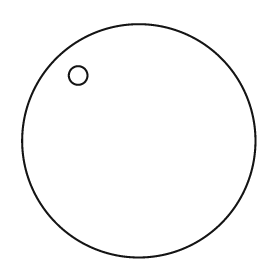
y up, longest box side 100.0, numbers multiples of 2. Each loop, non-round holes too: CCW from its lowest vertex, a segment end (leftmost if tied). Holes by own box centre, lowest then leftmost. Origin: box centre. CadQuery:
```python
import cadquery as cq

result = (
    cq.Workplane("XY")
    .moveTo(0.0, 0.0)
    .circle(50.0)
    .moveTo(-26.0, 28.0)
    .circle(4.0)
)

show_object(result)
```